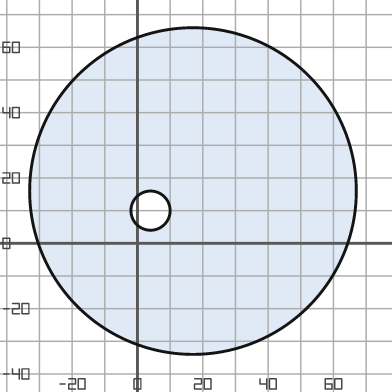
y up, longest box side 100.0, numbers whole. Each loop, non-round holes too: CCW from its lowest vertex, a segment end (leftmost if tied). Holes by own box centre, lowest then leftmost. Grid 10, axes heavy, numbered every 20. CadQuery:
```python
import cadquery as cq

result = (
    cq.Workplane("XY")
    .moveTo(17.0, 16.0)
    .circle(50.0)
    .moveTo(4.0, 10.0)
    .circle(6.0)
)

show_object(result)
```